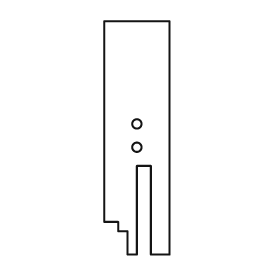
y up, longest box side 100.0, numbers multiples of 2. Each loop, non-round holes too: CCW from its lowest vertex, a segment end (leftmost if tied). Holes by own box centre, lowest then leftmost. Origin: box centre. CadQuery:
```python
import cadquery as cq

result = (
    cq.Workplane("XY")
    .moveTo(-4.0, -50.0)
    .lineTo(0.0, -50.0)
    .lineTo(0.0, -12.0)
    .lineTo(6.0, -12.0)
    .lineTo(6.0, -50.0)
    .lineTo(14.0, -50.0)
    .lineTo(14.0, 50.0)
    .lineTo(-14.0, 50.0)
    .lineTo(-14.0, -36.0)
    .lineTo(-8.0, -36.0)
    .lineTo(-8.0, -40.0)
    .lineTo(-4.0, -40.0)
    .close()
    .moveTo(0.0, -4.0)
    .circle(2.0)
    .moveTo(0.0, 6.0)
    .circle(2.0)
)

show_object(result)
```